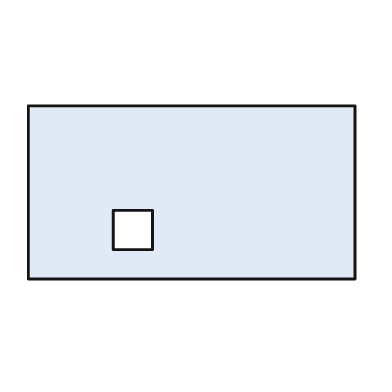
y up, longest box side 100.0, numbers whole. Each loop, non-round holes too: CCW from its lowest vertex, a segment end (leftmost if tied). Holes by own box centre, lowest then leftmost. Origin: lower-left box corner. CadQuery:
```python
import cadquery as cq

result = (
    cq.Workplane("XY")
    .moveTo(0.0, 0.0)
    .lineTo(100.0, 0.0)
    .lineTo(100.0, 53.0)
    .lineTo(0.0, 53.0)
    .close()
    .moveTo(26.0, 9.0)
    .lineTo(38.0, 9.0)
    .lineTo(38.0, 21.0)
    .lineTo(26.0, 21.0)
    .close()
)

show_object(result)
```